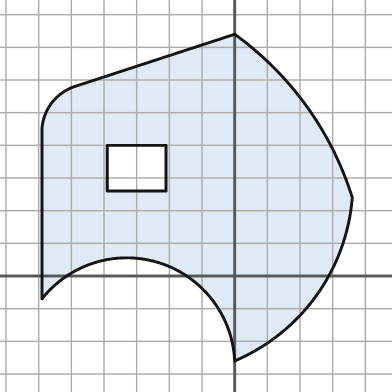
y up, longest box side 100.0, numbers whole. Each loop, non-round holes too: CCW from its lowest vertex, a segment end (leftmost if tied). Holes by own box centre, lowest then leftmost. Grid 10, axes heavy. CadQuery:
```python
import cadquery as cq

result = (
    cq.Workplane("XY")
    .moveTo(0.0, -26.0)
    .threePointArc((25.0, -6.0), (36.0, 24.0))
    .threePointArc((22.0, 52.0), (0.0, 74.0))
    .lineTo(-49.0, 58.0)
    .threePointArc((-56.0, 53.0), (-59.0, 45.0))
    .lineTo(-59.0, -7.0)
    .threePointArc((-23.0, 4.0), (0.0, -26.0))
    .close()
    .moveTo(-39.0, 26.0)
    .lineTo(-21.0, 26.0)
    .lineTo(-21.0, 40.0)
    .lineTo(-39.0, 40.0)
    .close()
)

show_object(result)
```